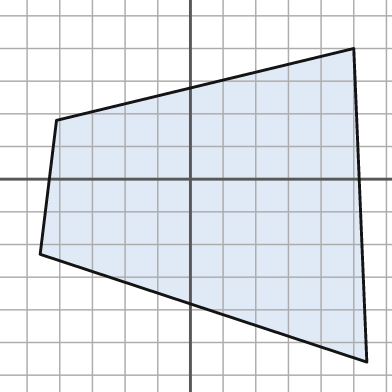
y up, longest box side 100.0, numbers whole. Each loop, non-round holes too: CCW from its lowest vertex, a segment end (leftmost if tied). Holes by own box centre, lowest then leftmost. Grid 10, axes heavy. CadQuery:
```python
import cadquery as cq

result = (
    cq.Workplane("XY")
    .moveTo(54.0, -56.0)
    .lineTo(50.0, 40.0)
    .lineTo(-41.0, 18.0)
    .lineTo(-46.0, -23.0)
    .close()
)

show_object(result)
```